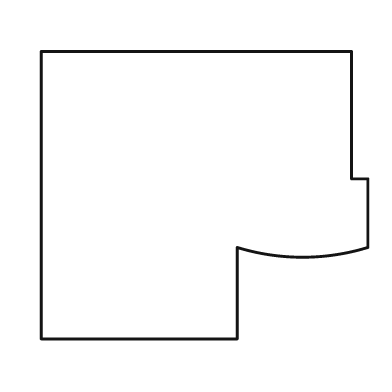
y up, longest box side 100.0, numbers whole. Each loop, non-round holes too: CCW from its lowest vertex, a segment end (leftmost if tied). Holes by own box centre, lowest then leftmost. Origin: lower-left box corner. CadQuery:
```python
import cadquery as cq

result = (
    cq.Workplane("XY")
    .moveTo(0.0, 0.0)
    .lineTo(60.0, 0.0)
    .lineTo(60.0, 28.0)
    .threePointArc((80.0, 25.0), (100.0, 28.0))
    .lineTo(100.0, 49.0)
    .lineTo(95.0, 49.0)
    .lineTo(95.0, 88.0)
    .lineTo(0.0, 88.0)
    .close()
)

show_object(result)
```